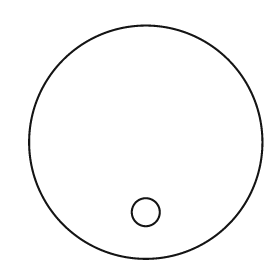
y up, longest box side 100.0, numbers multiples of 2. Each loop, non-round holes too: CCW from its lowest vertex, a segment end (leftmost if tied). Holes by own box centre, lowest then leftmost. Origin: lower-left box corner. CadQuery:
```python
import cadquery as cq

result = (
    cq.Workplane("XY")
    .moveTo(50.0, 50.0)
    .circle(50.0)
    .moveTo(50.0, 20.0)
    .circle(6.0)
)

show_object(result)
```